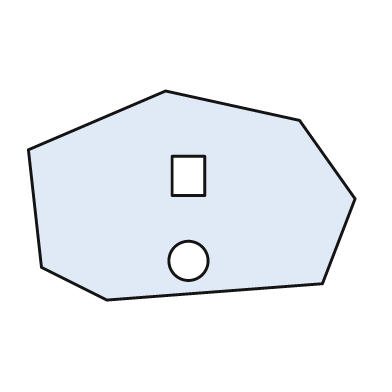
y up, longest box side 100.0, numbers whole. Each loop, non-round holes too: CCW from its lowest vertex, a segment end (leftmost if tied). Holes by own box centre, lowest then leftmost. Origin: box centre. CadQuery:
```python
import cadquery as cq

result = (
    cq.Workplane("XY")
    .moveTo(-26.0, -32.0)
    .lineTo(40.0, -27.0)
    .lineTo(50.0, -1.0)
    .lineTo(33.0, 23.0)
    .lineTo(-8.0, 32.0)
    .lineTo(-50.0, 14.0)
    .lineTo(-46.0, -22.0)
    .close()
    .moveTo(-1.0, -20.0)
    .circle(6.0)
    .moveTo(-6.0, 0.0)
    .lineTo(4.0, 0.0)
    .lineTo(4.0, 12.0)
    .lineTo(-6.0, 12.0)
    .close()
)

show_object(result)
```